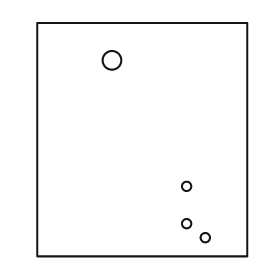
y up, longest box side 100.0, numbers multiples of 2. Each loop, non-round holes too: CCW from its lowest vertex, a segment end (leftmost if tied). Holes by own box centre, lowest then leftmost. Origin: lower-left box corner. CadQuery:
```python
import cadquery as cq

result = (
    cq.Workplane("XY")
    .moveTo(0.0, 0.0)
    .lineTo(90.0, 0.0)
    .lineTo(90.0, 100.0)
    .lineTo(0.0, 100.0)
    .close()
    .moveTo(72.0, 8.0)
    .circle(2.0)
    .moveTo(64.0, 14.0)
    .circle(2.0)
    .moveTo(64.0, 30.0)
    .circle(2.0)
    .moveTo(32.0, 84.0)
    .circle(4.0)
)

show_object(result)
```